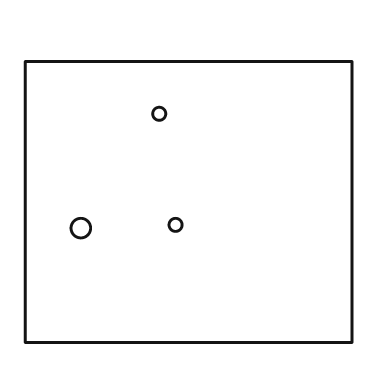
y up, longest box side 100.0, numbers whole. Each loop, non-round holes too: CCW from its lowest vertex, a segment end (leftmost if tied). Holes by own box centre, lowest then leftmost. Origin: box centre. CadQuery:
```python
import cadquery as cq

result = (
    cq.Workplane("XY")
    .moveTo(-50.0, -43.0)
    .lineTo(50.0, -43.0)
    .lineTo(50.0, 43.0)
    .lineTo(-50.0, 43.0)
    .close()
    .moveTo(-33.0, -8.0)
    .circle(3.0)
    .moveTo(-4.0, -7.0)
    .circle(2.0)
    .moveTo(-9.0, 27.0)
    .circle(2.0)
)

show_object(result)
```